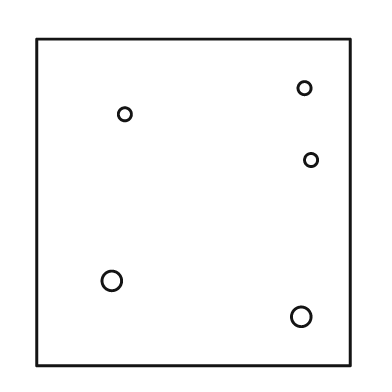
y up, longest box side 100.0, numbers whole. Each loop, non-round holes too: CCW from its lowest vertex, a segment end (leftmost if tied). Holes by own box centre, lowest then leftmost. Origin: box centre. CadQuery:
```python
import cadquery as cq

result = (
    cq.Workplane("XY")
    .moveTo(-48.0, -50.0)
    .lineTo(48.0, -50.0)
    .lineTo(48.0, 50.0)
    .lineTo(-48.0, 50.0)
    .close()
    .moveTo(33.0, -35.0)
    .circle(3.0)
    .moveTo(-25.0, -24.0)
    .circle(3.0)
    .moveTo(36.0, 13.0)
    .circle(2.0)
    .moveTo(-21.0, 27.0)
    .circle(2.0)
    .moveTo(34.0, 35.0)
    .circle(2.0)
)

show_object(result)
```